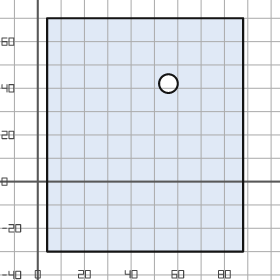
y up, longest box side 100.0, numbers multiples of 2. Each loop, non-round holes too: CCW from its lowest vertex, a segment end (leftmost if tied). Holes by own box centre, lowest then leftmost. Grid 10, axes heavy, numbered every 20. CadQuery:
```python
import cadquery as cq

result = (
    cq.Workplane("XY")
    .moveTo(4.0, -30.0)
    .lineTo(88.0, -30.0)
    .lineTo(88.0, 70.0)
    .lineTo(4.0, 70.0)
    .close()
    .moveTo(56.0, 42.0)
    .circle(4.0)
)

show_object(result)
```